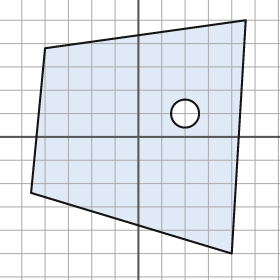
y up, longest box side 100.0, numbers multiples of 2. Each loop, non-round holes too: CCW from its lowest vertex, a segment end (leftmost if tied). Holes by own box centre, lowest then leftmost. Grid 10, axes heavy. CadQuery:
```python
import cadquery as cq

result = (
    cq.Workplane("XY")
    .moveTo(40.0, -50.0)
    .lineTo(46.0, 50.0)
    .lineTo(-40.0, 38.0)
    .lineTo(-46.0, -24.0)
    .close()
    .moveTo(20.0, 10.0)
    .circle(6.0)
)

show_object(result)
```